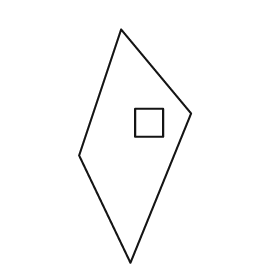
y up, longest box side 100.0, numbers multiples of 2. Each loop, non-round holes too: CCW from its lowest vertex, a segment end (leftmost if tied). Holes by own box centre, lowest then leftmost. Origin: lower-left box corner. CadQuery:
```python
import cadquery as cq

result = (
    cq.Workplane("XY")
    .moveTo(22.0, 0.0)
    .lineTo(48.0, 64.0)
    .lineTo(18.0, 100.0)
    .lineTo(0.0, 46.0)
    .close()
    .moveTo(24.0, 54.0)
    .lineTo(36.0, 54.0)
    .lineTo(36.0, 66.0)
    .lineTo(24.0, 66.0)
    .close()
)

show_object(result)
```